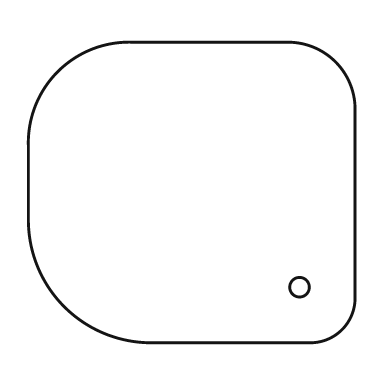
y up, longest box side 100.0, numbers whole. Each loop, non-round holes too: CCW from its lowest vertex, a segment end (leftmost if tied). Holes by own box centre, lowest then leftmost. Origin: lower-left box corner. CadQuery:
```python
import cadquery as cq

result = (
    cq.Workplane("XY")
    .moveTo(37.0, 0.0)
    .lineTo(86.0, 0.0)
    .threePointArc((96.0, 4.0), (100.0, 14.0))
    .lineTo(100.0, 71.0)
    .threePointArc((94.0, 86.0), (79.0, 92.0))
    .lineTo(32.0, 92.0)
    .threePointArc((9.0, 83.0), (0.0, 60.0))
    .lineTo(0.0, 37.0)
    .threePointArc((11.0, 11.0), (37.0, 0.0))
    .close()
    .moveTo(83.0, 17.0)
    .circle(3.0)
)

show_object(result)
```